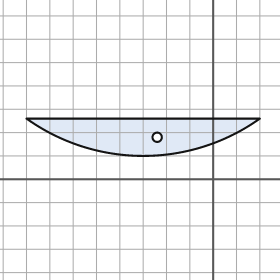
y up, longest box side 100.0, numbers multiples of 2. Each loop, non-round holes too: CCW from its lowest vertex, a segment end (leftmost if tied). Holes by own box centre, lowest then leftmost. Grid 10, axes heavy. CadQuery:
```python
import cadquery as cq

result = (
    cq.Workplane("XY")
    .moveTo(-80.0, 26.0)
    .threePointArc((-30.0, 10.0), (20.0, 26.0))
    .close()
    .moveTo(-24.0, 18.0)
    .circle(2.0)
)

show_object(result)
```